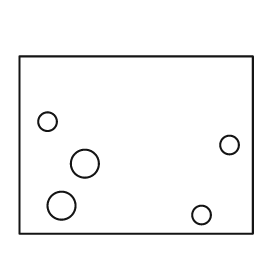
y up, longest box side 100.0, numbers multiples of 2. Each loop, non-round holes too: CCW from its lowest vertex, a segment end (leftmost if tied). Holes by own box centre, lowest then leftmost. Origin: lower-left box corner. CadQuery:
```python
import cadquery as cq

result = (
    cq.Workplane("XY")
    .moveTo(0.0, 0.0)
    .lineTo(100.0, 0.0)
    .lineTo(100.0, 76.0)
    .lineTo(0.0, 76.0)
    .close()
    .moveTo(78.0, 8.0)
    .circle(4.0)
    .moveTo(18.0, 12.0)
    .circle(6.0)
    .moveTo(28.0, 30.0)
    .circle(6.0)
    .moveTo(90.0, 38.0)
    .circle(4.0)
    .moveTo(12.0, 48.0)
    .circle(4.0)
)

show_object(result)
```